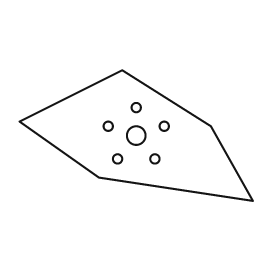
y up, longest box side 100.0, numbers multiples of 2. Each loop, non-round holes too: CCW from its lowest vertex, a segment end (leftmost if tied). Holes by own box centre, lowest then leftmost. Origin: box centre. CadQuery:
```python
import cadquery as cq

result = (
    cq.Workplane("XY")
    .moveTo(50.0, -28.0)
    .lineTo(32.0, 4.0)
    .lineTo(-6.0, 28.0)
    .lineTo(-50.0, 6.0)
    .lineTo(-16.0, -18.0)
    .close()
    .moveTo(-8.0, -10.0)
    .circle(2.0)
    .moveTo(8.0, -10.0)
    .circle(2.0)
    .moveTo(0.0, 0.0)
    .circle(4.0)
    .moveTo(-12.0, 4.0)
    .circle(2.0)
    .moveTo(12.0, 4.0)
    .circle(2.0)
    .moveTo(0.0, 12.0)
    .circle(2.0)
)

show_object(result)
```